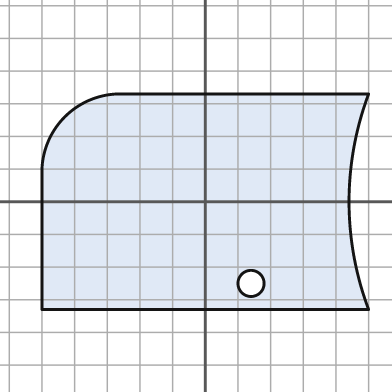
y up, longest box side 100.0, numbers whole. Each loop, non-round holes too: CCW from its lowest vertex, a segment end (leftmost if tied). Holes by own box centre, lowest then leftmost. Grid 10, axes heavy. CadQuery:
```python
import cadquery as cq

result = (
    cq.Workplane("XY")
    .moveTo(-50.0, -33.0)
    .lineTo(50.0, -33.0)
    .threePointArc((44.0, 0.0), (50.0, 33.0))
    .lineTo(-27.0, 33.0)
    .threePointArc((-43.0, 26.0), (-50.0, 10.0))
    .close()
    .moveTo(14.0, -25.0)
    .circle(4.0)
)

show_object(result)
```